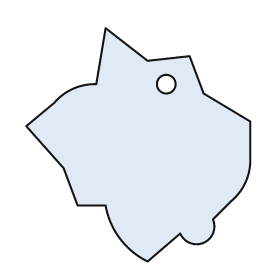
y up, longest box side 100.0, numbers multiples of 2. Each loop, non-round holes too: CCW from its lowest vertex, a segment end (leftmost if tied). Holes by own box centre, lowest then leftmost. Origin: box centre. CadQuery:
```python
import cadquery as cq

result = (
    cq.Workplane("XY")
    .moveTo(4.0, -50.0)
    .lineTo(18.0, -38.0)
    .threePointArc((28.0, -42.0), (32.0, -32.0))
    .lineTo(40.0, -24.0)
    .threePointArc((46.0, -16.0), (48.0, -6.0))
    .lineTo(48.0, 10.0)
    .lineTo(28.0, 22.0)
    .lineTo(22.0, 38.0)
    .lineTo(4.0, 36.0)
    .lineTo(-14.0, 50.0)
    .lineTo(-18.0, 26.0)
    .threePointArc((-28.0, 24.0), (-36.0, 18.0))
    .lineTo(-48.0, 8.0)
    .lineTo(-32.0, -10.0)
    .lineTo(-26.0, -26.0)
    .lineTo(-14.0, -26.0)
    .threePointArc((-8.0, -40.0), (4.0, -50.0))
    .close()
    .moveTo(12.0, 26.0)
    .circle(4.0)
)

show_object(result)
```